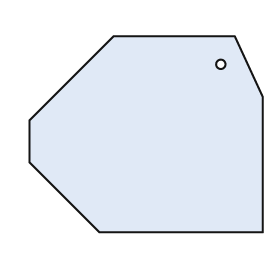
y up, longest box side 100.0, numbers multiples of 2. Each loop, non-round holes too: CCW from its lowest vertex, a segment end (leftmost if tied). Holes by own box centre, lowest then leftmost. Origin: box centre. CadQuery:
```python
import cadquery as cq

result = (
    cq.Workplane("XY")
    .moveTo(-20.0, -42.0)
    .lineTo(50.0, -42.0)
    .lineTo(50.0, 16.0)
    .lineTo(38.0, 42.0)
    .lineTo(-14.0, 42.0)
    .lineTo(-50.0, 6.0)
    .lineTo(-50.0, -12.0)
    .close()
    .moveTo(32.0, 30.0)
    .circle(2.0)
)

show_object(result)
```